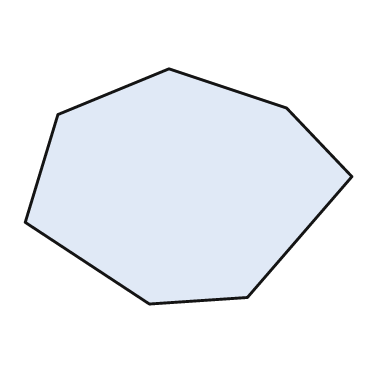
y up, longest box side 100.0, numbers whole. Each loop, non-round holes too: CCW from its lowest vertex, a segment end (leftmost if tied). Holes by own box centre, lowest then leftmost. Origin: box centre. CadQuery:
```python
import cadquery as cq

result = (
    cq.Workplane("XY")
    .moveTo(-12.0, -36.0)
    .lineTo(18.0, -34.0)
    .lineTo(50.0, 3.0)
    .lineTo(30.0, 24.0)
    .lineTo(-6.0, 36.0)
    .lineTo(-40.0, 22.0)
    .lineTo(-50.0, -11.0)
    .close()
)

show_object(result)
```